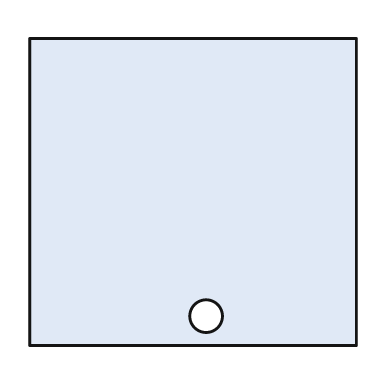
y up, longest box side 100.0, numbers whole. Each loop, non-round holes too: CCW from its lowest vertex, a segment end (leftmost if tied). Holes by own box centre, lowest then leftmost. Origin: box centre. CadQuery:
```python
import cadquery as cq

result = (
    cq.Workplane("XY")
    .moveTo(-50.0, -47.0)
    .lineTo(50.0, -47.0)
    .lineTo(50.0, 47.0)
    .lineTo(-50.0, 47.0)
    .close()
    .moveTo(4.0, -38.0)
    .circle(5.0)
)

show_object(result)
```